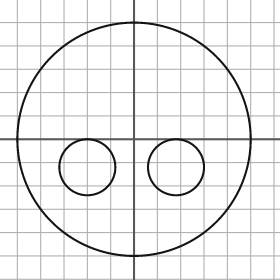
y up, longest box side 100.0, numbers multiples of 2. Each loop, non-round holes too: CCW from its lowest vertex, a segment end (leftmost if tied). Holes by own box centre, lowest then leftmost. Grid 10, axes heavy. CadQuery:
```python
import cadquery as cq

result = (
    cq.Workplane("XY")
    .moveTo(0.0, 0.0)
    .circle(50.0)
    .moveTo(-20.0, -12.0)
    .circle(12.0)
    .moveTo(18.0, -12.0)
    .circle(12.0)
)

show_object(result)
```